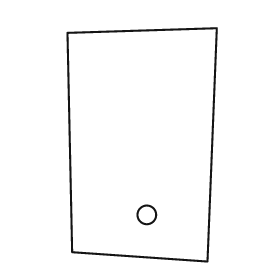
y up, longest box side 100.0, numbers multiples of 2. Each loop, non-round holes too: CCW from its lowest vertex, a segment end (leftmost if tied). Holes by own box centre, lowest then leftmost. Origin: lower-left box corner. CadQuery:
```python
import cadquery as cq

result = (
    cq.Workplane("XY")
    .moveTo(60.0, 0.0)
    .lineTo(64.0, 100.0)
    .lineTo(0.0, 98.0)
    .lineTo(2.0, 4.0)
    .close()
    .moveTo(34.0, 20.0)
    .circle(4.0)
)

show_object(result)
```